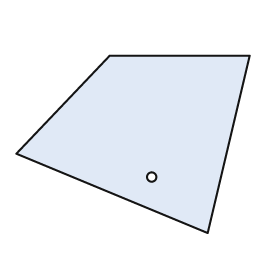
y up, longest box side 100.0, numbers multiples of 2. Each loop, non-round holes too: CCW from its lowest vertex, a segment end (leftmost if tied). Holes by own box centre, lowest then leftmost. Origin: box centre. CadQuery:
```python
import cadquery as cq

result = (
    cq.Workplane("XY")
    .moveTo(32.0, -38.0)
    .lineTo(50.0, 38.0)
    .lineTo(-10.0, 38.0)
    .lineTo(-50.0, -4.0)
    .close()
    .moveTo(8.0, -14.0)
    .circle(2.0)
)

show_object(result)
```